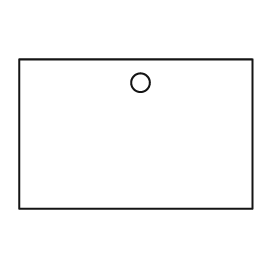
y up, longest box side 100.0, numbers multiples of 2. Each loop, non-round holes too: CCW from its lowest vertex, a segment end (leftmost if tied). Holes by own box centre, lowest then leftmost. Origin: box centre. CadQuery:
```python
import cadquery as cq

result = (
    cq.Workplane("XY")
    .moveTo(-50.0, -32.0)
    .lineTo(50.0, -32.0)
    .lineTo(50.0, 32.0)
    .lineTo(-50.0, 32.0)
    .close()
    .moveTo(2.0, 22.0)
    .circle(4.0)
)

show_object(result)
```